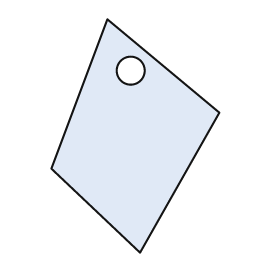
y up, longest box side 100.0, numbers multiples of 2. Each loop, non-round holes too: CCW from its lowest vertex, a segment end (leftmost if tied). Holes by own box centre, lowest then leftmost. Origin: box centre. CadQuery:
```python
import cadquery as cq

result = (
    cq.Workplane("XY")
    .moveTo(2.0, -50.0)
    .lineTo(36.0, 10.0)
    .lineTo(-12.0, 50.0)
    .lineTo(-36.0, -14.0)
    .close()
    .moveTo(-2.0, 28.0)
    .circle(6.0)
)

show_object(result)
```